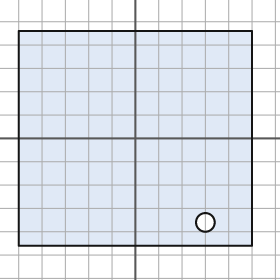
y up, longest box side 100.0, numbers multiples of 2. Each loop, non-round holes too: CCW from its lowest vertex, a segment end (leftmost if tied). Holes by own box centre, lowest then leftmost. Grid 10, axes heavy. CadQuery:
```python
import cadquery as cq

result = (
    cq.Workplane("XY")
    .moveTo(-50.0, -46.0)
    .lineTo(50.0, -46.0)
    .lineTo(50.0, 46.0)
    .lineTo(-50.0, 46.0)
    .close()
    .moveTo(30.0, -36.0)
    .circle(4.0)
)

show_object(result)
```